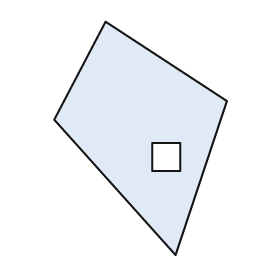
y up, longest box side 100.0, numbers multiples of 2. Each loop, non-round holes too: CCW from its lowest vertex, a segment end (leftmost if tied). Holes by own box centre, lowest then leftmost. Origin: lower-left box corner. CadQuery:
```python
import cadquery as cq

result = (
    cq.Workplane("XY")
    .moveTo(52.0, 0.0)
    .lineTo(74.0, 66.0)
    .lineTo(22.0, 100.0)
    .lineTo(0.0, 58.0)
    .close()
    .moveTo(42.0, 36.0)
    .lineTo(54.0, 36.0)
    .lineTo(54.0, 48.0)
    .lineTo(42.0, 48.0)
    .close()
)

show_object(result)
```